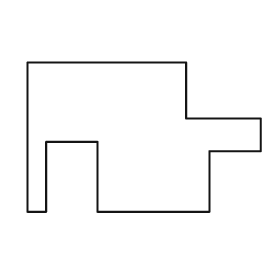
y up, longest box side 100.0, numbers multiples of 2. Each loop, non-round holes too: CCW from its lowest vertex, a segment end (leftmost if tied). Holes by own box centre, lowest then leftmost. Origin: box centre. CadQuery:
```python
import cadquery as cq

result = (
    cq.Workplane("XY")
    .moveTo(-50.0, -32.0)
    .lineTo(-42.0, -32.0)
    .lineTo(-42.0, -2.0)
    .lineTo(-20.0, -2.0)
    .lineTo(-20.0, -32.0)
    .lineTo(28.0, -32.0)
    .lineTo(28.0, -6.0)
    .lineTo(50.0, -6.0)
    .lineTo(50.0, 8.0)
    .lineTo(18.0, 8.0)
    .lineTo(18.0, 32.0)
    .lineTo(-50.0, 32.0)
    .close()
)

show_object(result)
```